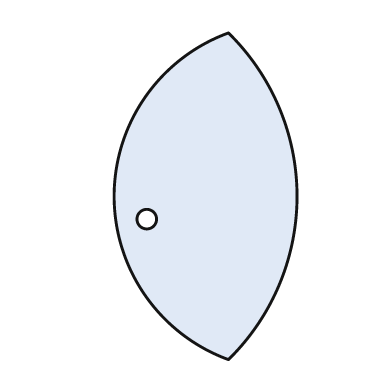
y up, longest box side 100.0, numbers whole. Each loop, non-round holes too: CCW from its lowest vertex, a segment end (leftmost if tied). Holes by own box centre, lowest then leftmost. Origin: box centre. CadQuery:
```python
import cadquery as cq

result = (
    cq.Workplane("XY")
    .moveTo(7.0, -50.0)
    .threePointArc((28.0, 0.0), (7.0, 50.0))
    .threePointArc((-28.0, 0.0), (7.0, -50.0))
    .close()
    .moveTo(-18.0, -7.0)
    .circle(3.0)
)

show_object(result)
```